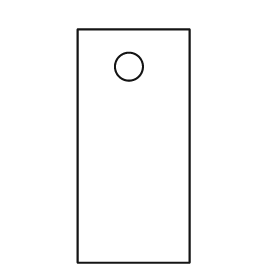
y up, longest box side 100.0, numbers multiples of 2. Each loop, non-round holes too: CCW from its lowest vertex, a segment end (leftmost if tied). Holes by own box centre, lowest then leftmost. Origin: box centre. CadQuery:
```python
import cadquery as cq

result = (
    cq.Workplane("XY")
    .moveTo(-24.0, -50.0)
    .lineTo(24.0, -50.0)
    .lineTo(24.0, 50.0)
    .lineTo(-24.0, 50.0)
    .close()
    .moveTo(-2.0, 34.0)
    .circle(6.0)
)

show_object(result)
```